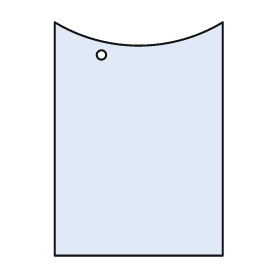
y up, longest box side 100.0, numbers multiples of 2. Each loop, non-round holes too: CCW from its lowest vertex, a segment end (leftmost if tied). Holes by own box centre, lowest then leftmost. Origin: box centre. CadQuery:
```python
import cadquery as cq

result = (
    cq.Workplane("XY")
    .moveTo(-36.0, -50.0)
    .lineTo(36.0, -50.0)
    .lineTo(36.0, 50.0)
    .threePointArc((0.0, 40.0), (-36.0, 50.0))
    .close()
    .moveTo(-16.0, 36.0)
    .circle(2.0)
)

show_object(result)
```